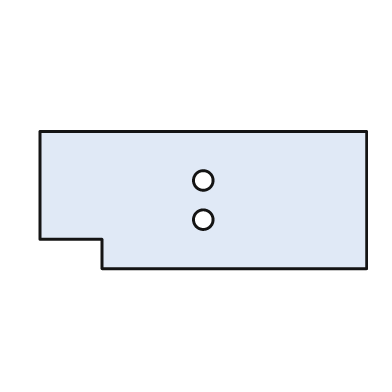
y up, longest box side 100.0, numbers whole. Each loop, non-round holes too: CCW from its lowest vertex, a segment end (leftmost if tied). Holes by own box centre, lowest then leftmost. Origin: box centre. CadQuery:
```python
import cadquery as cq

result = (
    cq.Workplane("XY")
    .moveTo(-31.0, -21.0)
    .lineTo(50.0, -21.0)
    .lineTo(50.0, 21.0)
    .lineTo(-50.0, 21.0)
    .lineTo(-50.0, -12.0)
    .lineTo(-31.0, -12.0)
    .close()
    .moveTo(0.0, -6.0)
    .circle(3.0)
    .moveTo(0.0, 6.0)
    .circle(3.0)
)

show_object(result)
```